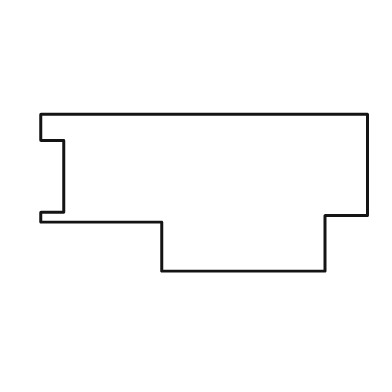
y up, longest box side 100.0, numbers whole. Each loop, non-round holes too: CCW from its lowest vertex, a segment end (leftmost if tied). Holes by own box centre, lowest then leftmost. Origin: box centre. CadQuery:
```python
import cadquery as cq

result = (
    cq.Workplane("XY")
    .moveTo(-13.0, -24.0)
    .lineTo(37.0, -24.0)
    .lineTo(37.0, -7.0)
    .lineTo(50.0, -7.0)
    .lineTo(50.0, 24.0)
    .lineTo(-50.0, 24.0)
    .lineTo(-50.0, 16.0)
    .lineTo(-43.0, 16.0)
    .lineTo(-43.0, -6.0)
    .lineTo(-50.0, -6.0)
    .lineTo(-50.0, -9.0)
    .lineTo(-13.0, -9.0)
    .close()
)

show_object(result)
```